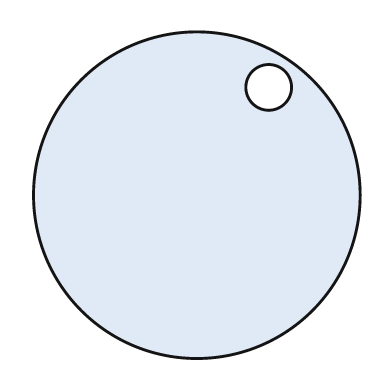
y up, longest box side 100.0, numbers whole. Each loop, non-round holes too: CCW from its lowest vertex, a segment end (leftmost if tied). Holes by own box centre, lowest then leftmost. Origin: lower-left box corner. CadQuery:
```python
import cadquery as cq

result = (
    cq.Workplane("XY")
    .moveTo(50.0, 50.0)
    .circle(50.0)
    .moveTo(72.0, 83.0)
    .circle(7.0)
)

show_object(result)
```